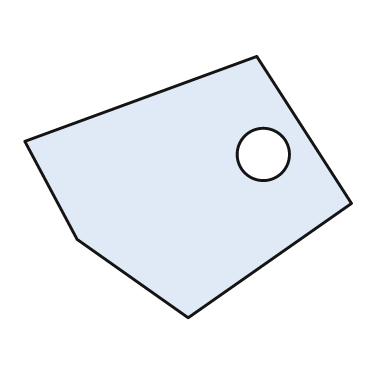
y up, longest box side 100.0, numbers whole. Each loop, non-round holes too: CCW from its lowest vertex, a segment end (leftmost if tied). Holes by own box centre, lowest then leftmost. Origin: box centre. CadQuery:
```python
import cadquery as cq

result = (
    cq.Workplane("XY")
    .moveTo(0.0, -40.0)
    .lineTo(50.0, -5.0)
    .lineTo(21.0, 40.0)
    .lineTo(-50.0, 14.0)
    .lineTo(-34.0, -16.0)
    .close()
    .moveTo(23.0, 10.0)
    .circle(8.0)
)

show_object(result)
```